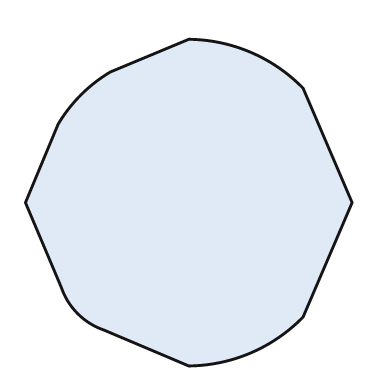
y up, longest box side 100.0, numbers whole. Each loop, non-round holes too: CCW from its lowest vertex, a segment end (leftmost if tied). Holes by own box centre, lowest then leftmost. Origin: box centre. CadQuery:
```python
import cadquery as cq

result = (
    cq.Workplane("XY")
    .moveTo(0.0, -50.0)
    .threePointArc((19.0, -46.0), (35.0, -35.0))
    .lineTo(50.0, 0.0)
    .lineTo(35.0, 35.0)
    .threePointArc((19.0, 46.0), (0.0, 50.0))
    .lineTo(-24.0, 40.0)
    .threePointArc((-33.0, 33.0), (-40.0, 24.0))
    .lineTo(-50.0, 0.0)
    .lineTo(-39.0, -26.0)
    .threePointArc((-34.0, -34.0), (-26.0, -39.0))
    .close()
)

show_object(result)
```